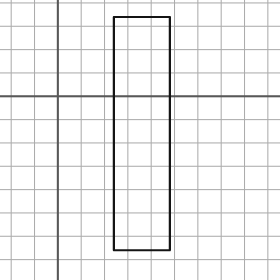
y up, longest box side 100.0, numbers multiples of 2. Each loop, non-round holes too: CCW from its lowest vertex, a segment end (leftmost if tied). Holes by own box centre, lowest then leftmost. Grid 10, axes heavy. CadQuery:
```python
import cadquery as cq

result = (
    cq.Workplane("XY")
    .moveTo(24.0, -66.0)
    .lineTo(48.0, -66.0)
    .lineTo(48.0, 34.0)
    .lineTo(24.0, 34.0)
    .close()
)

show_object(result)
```